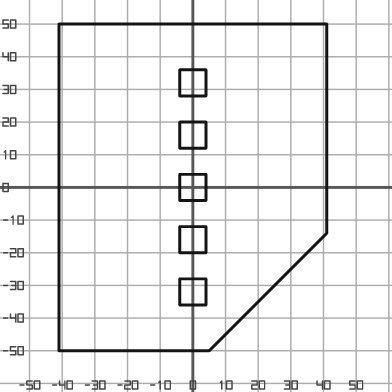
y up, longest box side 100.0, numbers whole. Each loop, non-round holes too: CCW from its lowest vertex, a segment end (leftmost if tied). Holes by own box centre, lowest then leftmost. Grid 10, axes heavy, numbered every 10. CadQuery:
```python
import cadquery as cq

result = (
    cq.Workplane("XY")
    .moveTo(-41.0, -50.0)
    .lineTo(5.0, -50.0)
    .lineTo(41.0, -14.0)
    .lineTo(41.0, 50.0)
    .lineTo(-41.0, 50.0)
    .close()
    .moveTo(-4.0, -36.0)
    .lineTo(4.0, -36.0)
    .lineTo(4.0, -28.0)
    .lineTo(-4.0, -28.0)
    .close()
    .moveTo(-4.0, -20.0)
    .lineTo(4.0, -20.0)
    .lineTo(4.0, -12.0)
    .lineTo(-4.0, -12.0)
    .close()
    .moveTo(-4.0, -4.0)
    .lineTo(4.0, -4.0)
    .lineTo(4.0, 4.0)
    .lineTo(-4.0, 4.0)
    .close()
    .moveTo(-4.0, 12.0)
    .lineTo(4.0, 12.0)
    .lineTo(4.0, 20.0)
    .lineTo(-4.0, 20.0)
    .close()
    .moveTo(-4.0, 28.0)
    .lineTo(4.0, 28.0)
    .lineTo(4.0, 36.0)
    .lineTo(-4.0, 36.0)
    .close()
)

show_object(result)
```